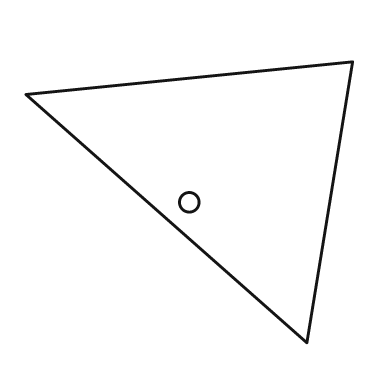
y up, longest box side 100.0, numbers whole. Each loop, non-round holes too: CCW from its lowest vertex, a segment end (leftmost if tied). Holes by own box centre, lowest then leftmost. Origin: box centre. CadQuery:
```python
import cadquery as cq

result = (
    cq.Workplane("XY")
    .moveTo(36.0, -43.0)
    .lineTo(50.0, 43.0)
    .lineTo(-50.0, 33.0)
    .close()
    .moveTo(0.0, 0.0)
    .circle(3.0)
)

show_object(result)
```